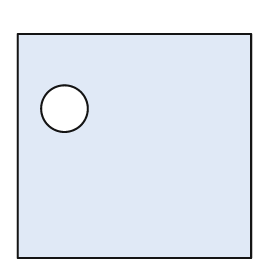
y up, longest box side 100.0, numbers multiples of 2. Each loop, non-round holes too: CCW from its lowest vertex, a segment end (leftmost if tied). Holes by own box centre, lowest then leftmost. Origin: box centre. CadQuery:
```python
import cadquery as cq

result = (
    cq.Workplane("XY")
    .moveTo(-50.0, -48.0)
    .lineTo(50.0, -48.0)
    .lineTo(50.0, 48.0)
    .lineTo(-50.0, 48.0)
    .close()
    .moveTo(-30.0, 16.0)
    .circle(10.0)
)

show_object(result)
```